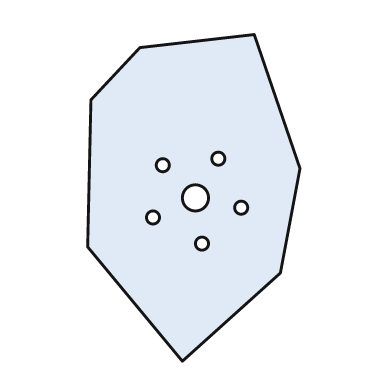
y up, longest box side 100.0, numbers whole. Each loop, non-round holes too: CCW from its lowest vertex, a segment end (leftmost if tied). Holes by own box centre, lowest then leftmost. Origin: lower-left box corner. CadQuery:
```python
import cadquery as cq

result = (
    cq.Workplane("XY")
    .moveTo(29.0, 0.0)
    .lineTo(59.0, 27.0)
    .lineTo(65.0, 59.0)
    .lineTo(51.0, 100.0)
    .lineTo(16.0, 96.0)
    .lineTo(1.0, 80.0)
    .lineTo(0.0, 35.0)
    .close()
    .moveTo(35.0, 36.0)
    .circle(2.0)
    .moveTo(20.0, 44.0)
    .circle(2.0)
    .moveTo(47.0, 47.0)
    .circle(2.0)
    .moveTo(33.0, 50.0)
    .circle(4.0)
    .moveTo(23.0, 60.0)
    .circle(2.0)
    .moveTo(40.0, 62.0)
    .circle(2.0)
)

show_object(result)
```